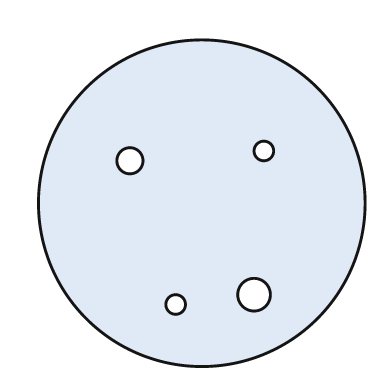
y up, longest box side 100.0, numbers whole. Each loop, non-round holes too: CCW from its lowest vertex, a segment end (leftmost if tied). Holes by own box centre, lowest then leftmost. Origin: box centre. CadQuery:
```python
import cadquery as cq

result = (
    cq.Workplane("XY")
    .moveTo(0.0, 0.0)
    .circle(50.0)
    .moveTo(-8.0, -31.0)
    .circle(3.0)
    .moveTo(16.0, -28.0)
    .circle(5.0)
    .moveTo(-22.0, 13.0)
    .circle(4.0)
    .moveTo(19.0, 16.0)
    .circle(3.0)
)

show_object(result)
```